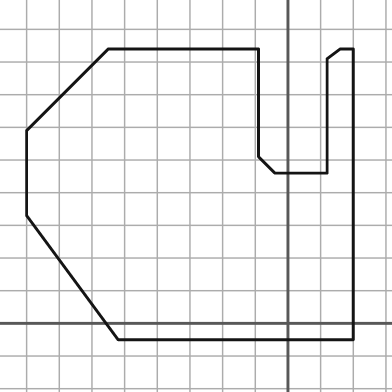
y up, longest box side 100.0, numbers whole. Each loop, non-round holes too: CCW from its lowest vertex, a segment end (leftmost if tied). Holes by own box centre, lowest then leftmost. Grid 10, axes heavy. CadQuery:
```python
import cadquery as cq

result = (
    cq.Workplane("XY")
    .moveTo(-52.0, -5.0)
    .lineTo(20.0, -5.0)
    .lineTo(20.0, 84.0)
    .lineTo(16.0, 84.0)
    .lineTo(12.0, 81.0)
    .lineTo(12.0, 46.0)
    .lineTo(-4.0, 46.0)
    .lineTo(-9.0, 51.0)
    .lineTo(-9.0, 84.0)
    .lineTo(-55.0, 84.0)
    .lineTo(-80.0, 59.0)
    .lineTo(-80.0, 33.0)
    .close()
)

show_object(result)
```